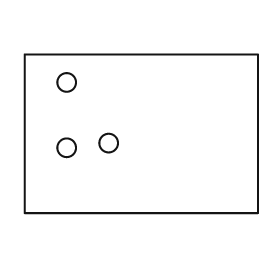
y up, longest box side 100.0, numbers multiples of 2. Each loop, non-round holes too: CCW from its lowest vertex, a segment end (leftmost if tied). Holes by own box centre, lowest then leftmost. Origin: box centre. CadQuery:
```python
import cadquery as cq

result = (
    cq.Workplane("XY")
    .moveTo(-50.0, -34.0)
    .lineTo(50.0, -34.0)
    .lineTo(50.0, 34.0)
    .lineTo(-50.0, 34.0)
    .close()
    .moveTo(-32.0, -6.0)
    .circle(4.0)
    .moveTo(-14.0, -4.0)
    .circle(4.0)
    .moveTo(-32.0, 22.0)
    .circle(4.0)
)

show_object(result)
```